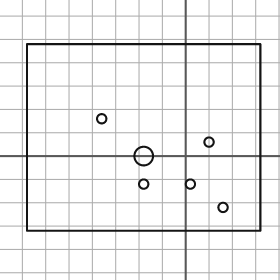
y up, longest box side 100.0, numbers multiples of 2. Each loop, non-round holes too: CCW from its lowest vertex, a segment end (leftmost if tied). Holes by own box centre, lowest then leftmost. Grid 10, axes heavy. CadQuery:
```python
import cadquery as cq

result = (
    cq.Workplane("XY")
    .moveTo(-68.0, -32.0)
    .lineTo(32.0, -32.0)
    .lineTo(32.0, 48.0)
    .lineTo(-68.0, 48.0)
    .close()
    .moveTo(16.0, -22.0)
    .circle(2.0)
    .moveTo(-18.0, -12.0)
    .circle(2.0)
    .moveTo(2.0, -12.0)
    .circle(2.0)
    .moveTo(-18.0, 0.0)
    .circle(4.0)
    .moveTo(10.0, 6.0)
    .circle(2.0)
    .moveTo(-36.0, 16.0)
    .circle(2.0)
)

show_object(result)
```